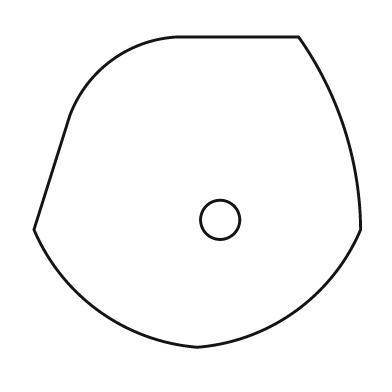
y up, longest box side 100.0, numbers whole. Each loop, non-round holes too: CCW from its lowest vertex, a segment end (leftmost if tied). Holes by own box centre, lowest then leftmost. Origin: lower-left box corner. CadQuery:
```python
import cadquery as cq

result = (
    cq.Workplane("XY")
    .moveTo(50.0, 0.0)
    .threePointArc((80.0, 11.0), (100.0, 36.0))
    .threePointArc((95.0, 67.0), (81.0, 95.0))
    .lineTo(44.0, 95.0)
    .threePointArc((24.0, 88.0), (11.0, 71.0))
    .lineTo(0.0, 36.0)
    .threePointArc((20.0, 11.0), (50.0, 0.0))
    .close()
    .moveTo(57.0, 39.0)
    .circle(6.0)
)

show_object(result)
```